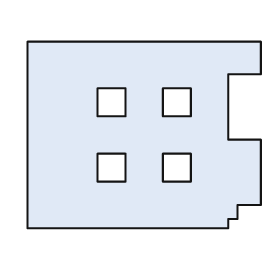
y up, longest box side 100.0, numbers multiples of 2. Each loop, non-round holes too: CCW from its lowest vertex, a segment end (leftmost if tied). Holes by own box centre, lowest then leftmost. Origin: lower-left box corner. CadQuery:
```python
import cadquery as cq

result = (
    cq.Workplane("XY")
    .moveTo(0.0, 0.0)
    .lineTo(86.0, 0.0)
    .lineTo(86.0, 4.0)
    .lineTo(90.0, 4.0)
    .lineTo(90.0, 10.0)
    .lineTo(100.0, 10.0)
    .lineTo(100.0, 38.0)
    .lineTo(86.0, 38.0)
    .lineTo(86.0, 66.0)
    .lineTo(100.0, 66.0)
    .lineTo(100.0, 80.0)
    .lineTo(0.0, 80.0)
    .close()
    .moveTo(30.0, 20.0)
    .lineTo(42.0, 20.0)
    .lineTo(42.0, 32.0)
    .lineTo(30.0, 32.0)
    .close()
    .moveTo(58.0, 20.0)
    .lineTo(70.0, 20.0)
    .lineTo(70.0, 32.0)
    .lineTo(58.0, 32.0)
    .close()
    .moveTo(30.0, 48.0)
    .lineTo(42.0, 48.0)
    .lineTo(42.0, 60.0)
    .lineTo(30.0, 60.0)
    .close()
    .moveTo(58.0, 48.0)
    .lineTo(70.0, 48.0)
    .lineTo(70.0, 60.0)
    .lineTo(58.0, 60.0)
    .close()
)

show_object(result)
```